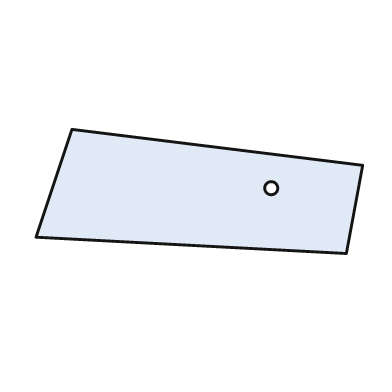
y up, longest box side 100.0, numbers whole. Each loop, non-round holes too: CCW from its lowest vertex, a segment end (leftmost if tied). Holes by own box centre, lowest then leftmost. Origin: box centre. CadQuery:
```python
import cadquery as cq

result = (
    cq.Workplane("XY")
    .moveTo(45.0, -19.0)
    .lineTo(50.0, 8.0)
    .lineTo(-39.0, 19.0)
    .lineTo(-50.0, -14.0)
    .close()
    .moveTo(22.0, 1.0)
    .circle(2.0)
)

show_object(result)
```